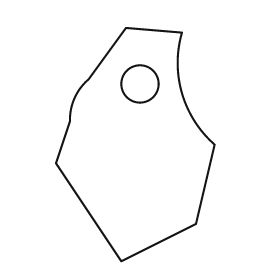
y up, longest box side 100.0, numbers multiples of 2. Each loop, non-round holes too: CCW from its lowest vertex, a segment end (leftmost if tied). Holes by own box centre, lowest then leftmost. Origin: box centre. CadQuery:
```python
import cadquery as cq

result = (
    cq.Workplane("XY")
    .moveTo(-6.0, -50.0)
    .lineTo(26.0, -34.0)
    .lineTo(34.0, 0.0)
    .threePointArc((20.0, 22.0), (20.0, 48.0))
    .lineTo(-4.0, 50.0)
    .lineTo(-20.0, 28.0)
    .threePointArc((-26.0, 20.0), (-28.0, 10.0))
    .lineTo(-34.0, -8.0)
    .close()
    .moveTo(2.0, 26.0)
    .circle(8.0)
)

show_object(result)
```